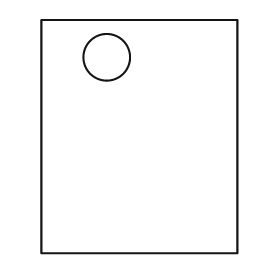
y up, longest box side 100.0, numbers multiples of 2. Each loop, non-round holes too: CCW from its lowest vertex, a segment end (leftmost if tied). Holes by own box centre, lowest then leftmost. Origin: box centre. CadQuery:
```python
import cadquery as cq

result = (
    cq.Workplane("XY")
    .moveTo(-42.0, -50.0)
    .lineTo(42.0, -50.0)
    .lineTo(42.0, 50.0)
    .lineTo(-42.0, 50.0)
    .close()
    .moveTo(-14.0, 34.0)
    .circle(10.0)
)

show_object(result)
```